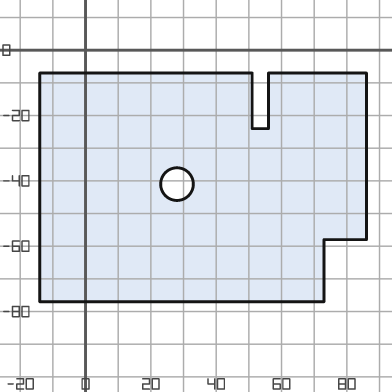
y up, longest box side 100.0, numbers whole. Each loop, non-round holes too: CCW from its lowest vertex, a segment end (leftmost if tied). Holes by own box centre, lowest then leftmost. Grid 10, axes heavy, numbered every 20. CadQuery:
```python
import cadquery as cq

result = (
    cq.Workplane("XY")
    .moveTo(-14.0, -77.0)
    .lineTo(73.0, -77.0)
    .lineTo(73.0, -58.0)
    .lineTo(86.0, -58.0)
    .lineTo(86.0, -7.0)
    .lineTo(56.0, -7.0)
    .lineTo(56.0, -24.0)
    .lineTo(51.0, -24.0)
    .lineTo(51.0, -7.0)
    .lineTo(-14.0, -7.0)
    .close()
    .moveTo(28.0, -41.0)
    .circle(5.0)
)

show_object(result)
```